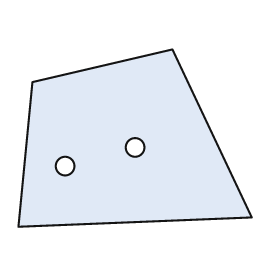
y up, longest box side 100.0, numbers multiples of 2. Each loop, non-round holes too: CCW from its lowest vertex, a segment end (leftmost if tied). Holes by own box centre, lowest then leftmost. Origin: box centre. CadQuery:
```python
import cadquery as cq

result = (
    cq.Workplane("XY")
    .moveTo(-50.0, -38.0)
    .lineTo(50.0, -34.0)
    .lineTo(16.0, 38.0)
    .lineTo(-44.0, 24.0)
    .close()
    .moveTo(-30.0, -12.0)
    .circle(4.0)
    .moveTo(0.0, -4.0)
    .circle(4.0)
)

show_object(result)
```